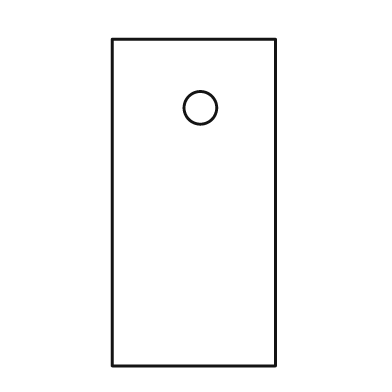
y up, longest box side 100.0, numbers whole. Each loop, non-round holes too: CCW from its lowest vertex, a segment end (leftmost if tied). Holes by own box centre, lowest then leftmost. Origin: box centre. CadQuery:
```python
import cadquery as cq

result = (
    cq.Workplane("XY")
    .moveTo(-25.0, -50.0)
    .lineTo(25.0, -50.0)
    .lineTo(25.0, 50.0)
    .lineTo(-25.0, 50.0)
    .close()
    .moveTo(2.0, 29.0)
    .circle(5.0)
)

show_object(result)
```